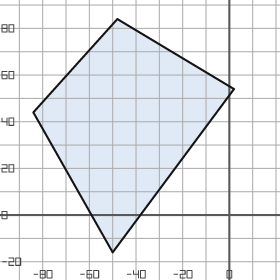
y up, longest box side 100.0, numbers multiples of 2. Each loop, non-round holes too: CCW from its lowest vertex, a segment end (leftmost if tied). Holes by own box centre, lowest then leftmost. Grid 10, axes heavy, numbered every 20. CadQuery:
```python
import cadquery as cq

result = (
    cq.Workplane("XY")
    .moveTo(-50.0, -16.0)
    .lineTo(2.0, 54.0)
    .lineTo(-48.0, 84.0)
    .lineTo(-84.0, 44.0)
    .close()
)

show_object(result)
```